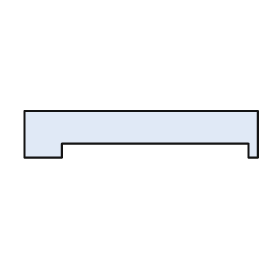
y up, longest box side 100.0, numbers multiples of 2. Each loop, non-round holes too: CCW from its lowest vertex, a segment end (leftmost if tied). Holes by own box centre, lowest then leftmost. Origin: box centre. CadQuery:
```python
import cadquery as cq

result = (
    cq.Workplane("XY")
    .moveTo(-50.0, -10.0)
    .lineTo(-34.0, -10.0)
    .lineTo(-34.0, -4.0)
    .lineTo(46.0, -4.0)
    .lineTo(46.0, -10.0)
    .lineTo(50.0, -10.0)
    .lineTo(50.0, 10.0)
    .lineTo(-50.0, 10.0)
    .close()
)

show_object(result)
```